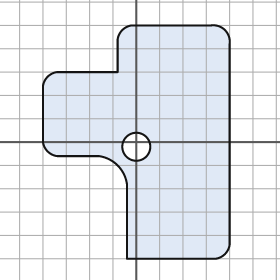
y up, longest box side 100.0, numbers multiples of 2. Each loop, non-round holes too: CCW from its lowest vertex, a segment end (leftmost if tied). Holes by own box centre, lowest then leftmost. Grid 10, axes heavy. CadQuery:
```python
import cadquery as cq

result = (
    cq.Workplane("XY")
    .moveTo(-4.0, -50.0)
    .lineTo(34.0, -50.0)
    .threePointArc((38.0, -48.0), (40.0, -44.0))
    .lineTo(40.0, 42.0)
    .threePointArc((38.0, 48.0), (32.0, 50.0))
    .lineTo(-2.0, 50.0)
    .threePointArc((-6.0, 48.0), (-8.0, 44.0))
    .lineTo(-8.0, 30.0)
    .lineTo(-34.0, 30.0)
    .threePointArc((-38.0, 28.0), (-40.0, 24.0))
    .lineTo(-40.0, 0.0)
    .threePointArc((-38.0, -4.0), (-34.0, -6.0))
    .lineTo(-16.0, -6.0)
    .threePointArc((-8.0, -10.0), (-4.0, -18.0))
    .close()
    .moveTo(0.0, -2.0)
    .circle(6.0)
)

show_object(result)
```